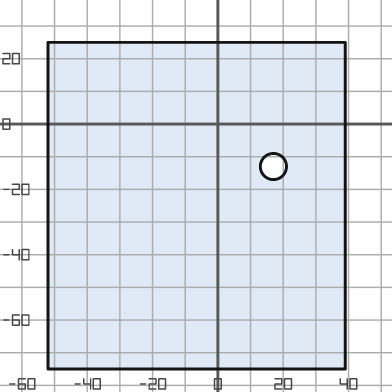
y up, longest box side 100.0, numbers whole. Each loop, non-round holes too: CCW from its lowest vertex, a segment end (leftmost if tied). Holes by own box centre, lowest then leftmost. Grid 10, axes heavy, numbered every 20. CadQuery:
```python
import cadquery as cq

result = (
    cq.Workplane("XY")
    .moveTo(-52.0, -75.0)
    .lineTo(39.0, -75.0)
    .lineTo(39.0, 25.0)
    .lineTo(-52.0, 25.0)
    .close()
    .moveTo(17.0, -13.0)
    .circle(4.0)
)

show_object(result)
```